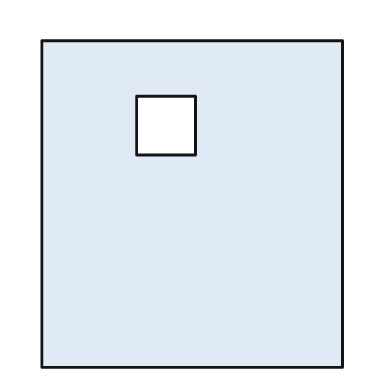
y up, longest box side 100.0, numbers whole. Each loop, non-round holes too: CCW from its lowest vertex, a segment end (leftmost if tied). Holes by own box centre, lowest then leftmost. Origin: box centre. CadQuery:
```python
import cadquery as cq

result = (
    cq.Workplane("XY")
    .moveTo(-46.0, -50.0)
    .lineTo(46.0, -50.0)
    .lineTo(46.0, 50.0)
    .lineTo(-46.0, 50.0)
    .close()
    .moveTo(-17.0, 15.0)
    .lineTo(1.0, 15.0)
    .lineTo(1.0, 33.0)
    .lineTo(-17.0, 33.0)
    .close()
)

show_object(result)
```